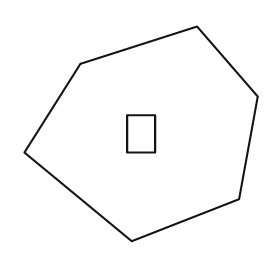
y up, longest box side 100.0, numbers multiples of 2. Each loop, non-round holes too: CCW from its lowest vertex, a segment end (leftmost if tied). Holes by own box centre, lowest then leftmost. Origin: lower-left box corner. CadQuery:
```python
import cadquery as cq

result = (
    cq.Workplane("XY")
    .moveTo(46.0, 0.0)
    .lineTo(92.0, 18.0)
    .lineTo(100.0, 62.0)
    .lineTo(74.0, 92.0)
    .lineTo(24.0, 76.0)
    .lineTo(0.0, 38.0)
    .close()
    .moveTo(44.0, 38.0)
    .lineTo(56.0, 38.0)
    .lineTo(56.0, 54.0)
    .lineTo(44.0, 54.0)
    .close()
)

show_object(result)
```